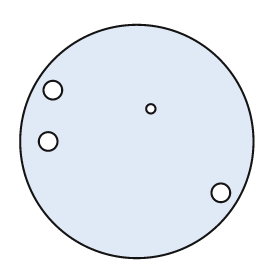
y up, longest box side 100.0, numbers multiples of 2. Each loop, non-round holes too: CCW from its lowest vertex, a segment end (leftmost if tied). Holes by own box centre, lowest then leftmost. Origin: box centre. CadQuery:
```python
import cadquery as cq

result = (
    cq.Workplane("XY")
    .moveTo(0.0, 0.0)
    .circle(50.0)
    .moveTo(36.0, -22.0)
    .circle(4.0)
    .moveTo(-38.0, 0.0)
    .circle(4.0)
    .moveTo(6.0, 14.0)
    .circle(2.0)
    .moveTo(-36.0, 22.0)
    .circle(4.0)
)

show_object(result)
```